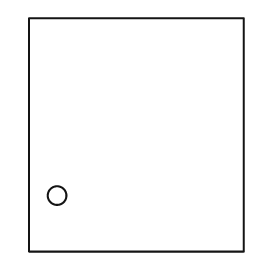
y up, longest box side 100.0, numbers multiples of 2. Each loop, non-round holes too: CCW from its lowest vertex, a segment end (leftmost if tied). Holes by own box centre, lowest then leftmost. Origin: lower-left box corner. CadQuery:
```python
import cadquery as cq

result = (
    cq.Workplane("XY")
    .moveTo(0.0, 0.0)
    .lineTo(92.0, 0.0)
    .lineTo(92.0, 100.0)
    .lineTo(0.0, 100.0)
    .close()
    .moveTo(12.0, 24.0)
    .circle(4.0)
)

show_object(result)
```